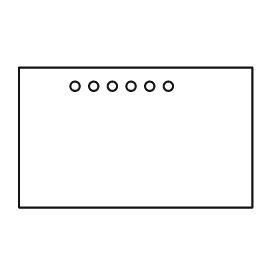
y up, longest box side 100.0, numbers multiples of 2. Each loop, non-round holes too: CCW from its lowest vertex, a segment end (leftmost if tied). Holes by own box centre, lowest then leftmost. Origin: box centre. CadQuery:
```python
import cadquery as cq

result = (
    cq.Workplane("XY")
    .moveTo(-50.0, -30.0)
    .lineTo(50.0, -30.0)
    .lineTo(50.0, 30.0)
    .lineTo(-50.0, 30.0)
    .close()
    .moveTo(-26.0, 22.0)
    .circle(2.0)
    .moveTo(-18.0, 22.0)
    .circle(2.0)
    .moveTo(-10.0, 22.0)
    .circle(2.0)
    .moveTo(-2.0, 22.0)
    .circle(2.0)
    .moveTo(6.0, 22.0)
    .circle(2.0)
    .moveTo(14.0, 22.0)
    .circle(2.0)
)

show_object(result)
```